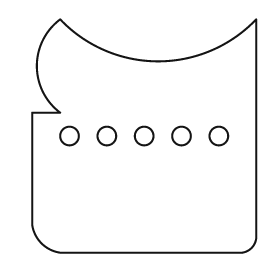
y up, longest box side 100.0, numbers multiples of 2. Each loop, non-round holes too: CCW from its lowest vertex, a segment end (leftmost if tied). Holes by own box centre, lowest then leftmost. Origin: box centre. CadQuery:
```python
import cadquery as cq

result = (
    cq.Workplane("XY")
    .moveTo(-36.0, -50.0)
    .lineTo(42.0, -50.0)
    .threePointArc((46.0, -48.0), (48.0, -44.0))
    .lineTo(48.0, 50.0)
    .threePointArc((6.0, 32.0), (-36.0, 50.0))
    .threePointArc((-46.0, 30.0), (-36.0, 10.0))
    .lineTo(-48.0, 10.0)
    .lineTo(-48.0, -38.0)
    .threePointArc((-44.0, -46.0), (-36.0, -50.0))
    .close()
    .moveTo(-32.0, 0.0)
    .circle(4.0)
    .moveTo(-16.0, 0.0)
    .circle(4.0)
    .moveTo(0.0, 0.0)
    .circle(4.0)
    .moveTo(16.0, 0.0)
    .circle(4.0)
    .moveTo(32.0, 0.0)
    .circle(4.0)
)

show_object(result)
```